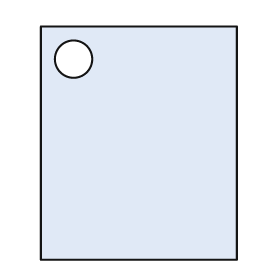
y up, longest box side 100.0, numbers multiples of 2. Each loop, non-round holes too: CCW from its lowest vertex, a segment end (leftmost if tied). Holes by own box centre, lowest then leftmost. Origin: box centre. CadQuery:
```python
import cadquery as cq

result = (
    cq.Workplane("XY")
    .moveTo(-42.0, -50.0)
    .lineTo(42.0, -50.0)
    .lineTo(42.0, 50.0)
    .lineTo(-42.0, 50.0)
    .close()
    .moveTo(-28.0, 36.0)
    .circle(8.0)
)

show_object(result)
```